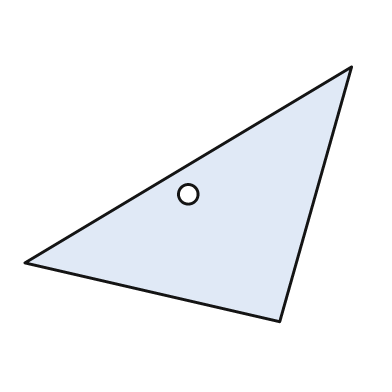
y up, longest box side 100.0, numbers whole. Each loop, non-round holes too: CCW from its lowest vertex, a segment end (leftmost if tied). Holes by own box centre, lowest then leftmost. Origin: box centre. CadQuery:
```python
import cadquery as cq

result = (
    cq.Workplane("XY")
    .moveTo(28.0, -39.0)
    .lineTo(50.0, 39.0)
    .lineTo(-50.0, -21.0)
    .close()
    .moveTo(0.0, 0.0)
    .circle(3.0)
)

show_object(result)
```